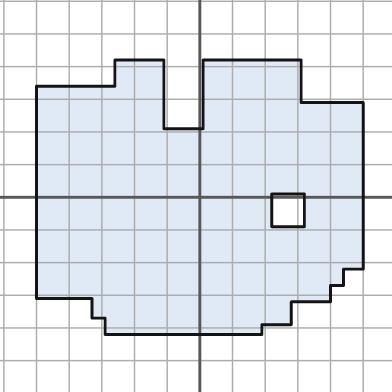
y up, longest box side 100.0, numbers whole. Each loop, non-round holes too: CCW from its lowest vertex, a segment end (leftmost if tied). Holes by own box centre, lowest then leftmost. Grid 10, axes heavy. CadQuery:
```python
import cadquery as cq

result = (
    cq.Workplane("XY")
    .moveTo(-29.0, -42.0)
    .lineTo(19.0, -42.0)
    .lineTo(19.0, -39.0)
    .lineTo(28.0, -39.0)
    .lineTo(28.0, -32.0)
    .lineTo(40.0, -32.0)
    .lineTo(40.0, -27.0)
    .lineTo(44.0, -27.0)
    .lineTo(44.0, -22.0)
    .lineTo(50.0, -22.0)
    .lineTo(50.0, 29.0)
    .lineTo(31.0, 29.0)
    .lineTo(31.0, 42.0)
    .lineTo(1.0, 42.0)
    .lineTo(1.0, 21.0)
    .lineTo(-11.0, 21.0)
    .lineTo(-11.0, 42.0)
    .lineTo(-26.0, 42.0)
    .lineTo(-26.0, 34.0)
    .lineTo(-50.0, 34.0)
    .lineTo(-50.0, -31.0)
    .lineTo(-33.0, -31.0)
    .lineTo(-33.0, -37.0)
    .lineTo(-29.0, -37.0)
    .close()
    .moveTo(22.0, -9.0)
    .lineTo(32.0, -9.0)
    .lineTo(32.0, 1.0)
    .lineTo(22.0, 1.0)
    .close()
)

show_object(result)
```